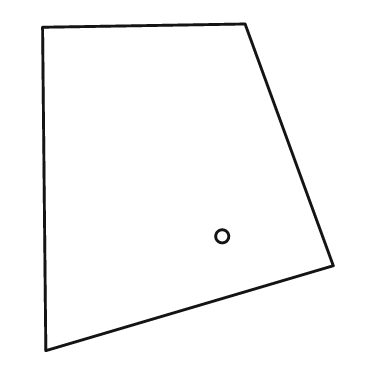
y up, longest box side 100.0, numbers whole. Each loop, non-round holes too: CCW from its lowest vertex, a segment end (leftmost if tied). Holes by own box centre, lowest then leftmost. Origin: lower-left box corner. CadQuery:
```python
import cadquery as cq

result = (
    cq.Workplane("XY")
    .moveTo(1.0, 0.0)
    .lineTo(89.0, 26.0)
    .lineTo(62.0, 100.0)
    .lineTo(0.0, 99.0)
    .close()
    .moveTo(55.0, 35.0)
    .circle(2.0)
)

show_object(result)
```